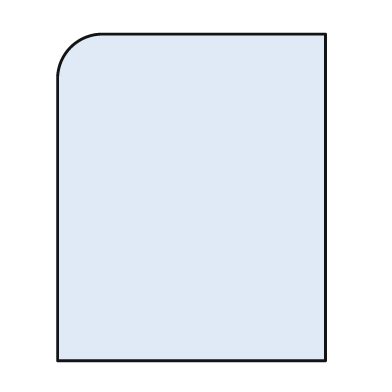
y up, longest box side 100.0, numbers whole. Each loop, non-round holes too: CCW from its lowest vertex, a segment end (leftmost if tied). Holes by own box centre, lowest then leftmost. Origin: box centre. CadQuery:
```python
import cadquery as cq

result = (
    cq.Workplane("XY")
    .moveTo(-41.0, -50.0)
    .lineTo(41.0, -50.0)
    .lineTo(41.0, 50.0)
    .lineTo(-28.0, 50.0)
    .threePointArc((-37.0, 46.0), (-41.0, 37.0))
    .close()
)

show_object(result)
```